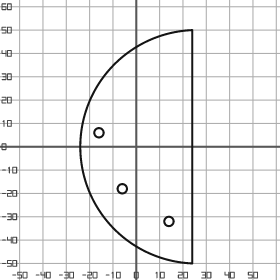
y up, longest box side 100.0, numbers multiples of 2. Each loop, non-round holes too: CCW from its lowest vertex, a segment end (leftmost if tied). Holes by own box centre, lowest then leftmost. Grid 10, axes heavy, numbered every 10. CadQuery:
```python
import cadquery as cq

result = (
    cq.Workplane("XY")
    .moveTo(24.0, -50.0)
    .lineTo(24.0, 50.0)
    .threePointArc((-24.0, 0.0), (24.0, -50.0))
    .close()
    .moveTo(14.0, -32.0)
    .circle(2.0)
    .moveTo(-6.0, -18.0)
    .circle(2.0)
    .moveTo(-16.0, 6.0)
    .circle(2.0)
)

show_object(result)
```